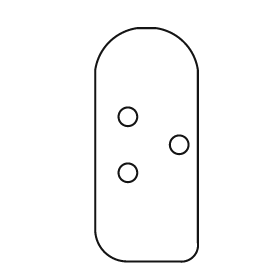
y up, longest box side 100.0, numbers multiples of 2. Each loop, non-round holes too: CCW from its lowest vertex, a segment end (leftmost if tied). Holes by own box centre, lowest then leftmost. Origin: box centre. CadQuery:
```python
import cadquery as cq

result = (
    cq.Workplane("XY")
    .moveTo(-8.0, -50.0)
    .lineTo(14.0, -50.0)
    .threePointArc((20.0, -48.0), (22.0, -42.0))
    .lineTo(22.0, 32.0)
    .threePointArc((16.0, 44.0), (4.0, 50.0))
    .lineTo(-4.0, 50.0)
    .threePointArc((-16.0, 44.0), (-22.0, 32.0))
    .lineTo(-22.0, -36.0)
    .threePointArc((-18.0, -46.0), (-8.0, -50.0))
    .close()
    .moveTo(-8.0, -12.0)
    .circle(4.0)
    .moveTo(14.0, 0.0)
    .circle(4.0)
    .moveTo(-8.0, 12.0)
    .circle(4.0)
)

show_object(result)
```